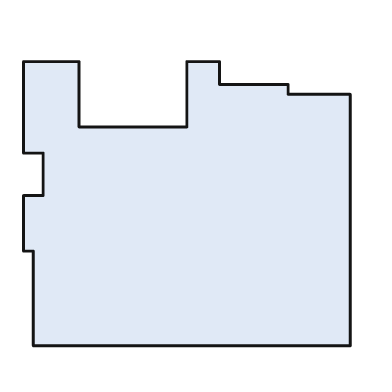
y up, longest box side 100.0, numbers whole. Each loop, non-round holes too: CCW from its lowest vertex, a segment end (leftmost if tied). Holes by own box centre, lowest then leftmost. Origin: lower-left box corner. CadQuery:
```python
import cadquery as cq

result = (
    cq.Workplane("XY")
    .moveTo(3.0, 0.0)
    .lineTo(100.0, 0.0)
    .lineTo(100.0, 77.0)
    .lineTo(81.0, 77.0)
    .lineTo(81.0, 80.0)
    .lineTo(60.0, 80.0)
    .lineTo(60.0, 87.0)
    .lineTo(50.0, 87.0)
    .lineTo(50.0, 67.0)
    .lineTo(17.0, 67.0)
    .lineTo(17.0, 87.0)
    .lineTo(0.0, 87.0)
    .lineTo(0.0, 59.0)
    .lineTo(6.0, 59.0)
    .lineTo(6.0, 46.0)
    .lineTo(0.0, 46.0)
    .lineTo(0.0, 29.0)
    .lineTo(3.0, 29.0)
    .close()
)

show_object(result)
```